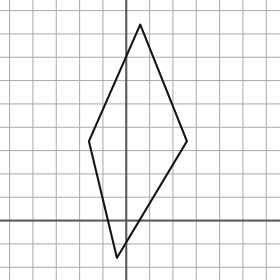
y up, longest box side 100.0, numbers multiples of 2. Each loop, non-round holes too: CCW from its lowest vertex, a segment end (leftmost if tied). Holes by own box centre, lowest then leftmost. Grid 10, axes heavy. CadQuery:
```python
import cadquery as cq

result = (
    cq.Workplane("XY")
    .moveTo(-4.0, -16.0)
    .lineTo(26.0, 34.0)
    .lineTo(6.0, 84.0)
    .lineTo(-16.0, 34.0)
    .close()
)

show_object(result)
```